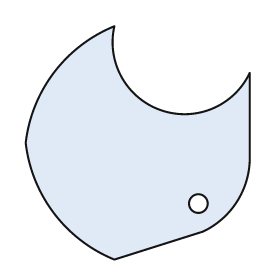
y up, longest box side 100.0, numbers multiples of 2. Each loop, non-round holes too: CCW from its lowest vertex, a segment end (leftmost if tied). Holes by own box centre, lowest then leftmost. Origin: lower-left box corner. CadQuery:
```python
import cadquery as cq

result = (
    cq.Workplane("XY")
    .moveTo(38.0, 0.0)
    .lineTo(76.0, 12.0)
    .threePointArc((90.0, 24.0), (96.0, 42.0))
    .lineTo(96.0, 80.0)
    .threePointArc((58.0, 64.0), (38.0, 100.0))
    .threePointArc((12.0, 80.0), (0.0, 50.0))
    .threePointArc((12.0, 20.0), (38.0, 0.0))
    .close()
    .moveTo(74.0, 24.0)
    .circle(4.0)
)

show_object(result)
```